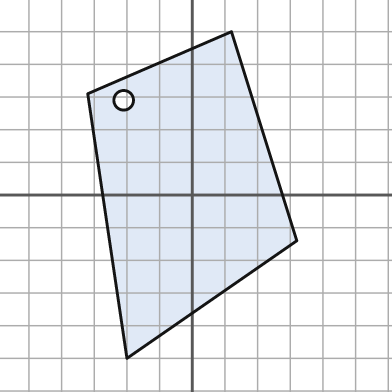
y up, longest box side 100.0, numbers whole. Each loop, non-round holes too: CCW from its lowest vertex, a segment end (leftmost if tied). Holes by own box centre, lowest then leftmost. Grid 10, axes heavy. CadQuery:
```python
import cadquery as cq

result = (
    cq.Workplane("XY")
    .moveTo(-20.0, -50.0)
    .lineTo(32.0, -14.0)
    .lineTo(12.0, 50.0)
    .lineTo(-32.0, 31.0)
    .close()
    .moveTo(-21.0, 29.0)
    .circle(3.0)
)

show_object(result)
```